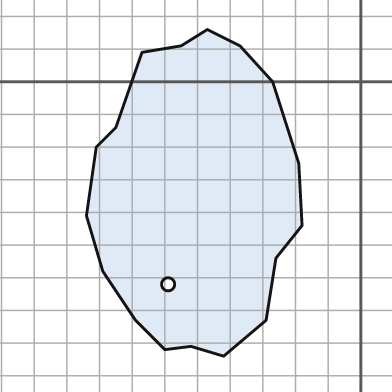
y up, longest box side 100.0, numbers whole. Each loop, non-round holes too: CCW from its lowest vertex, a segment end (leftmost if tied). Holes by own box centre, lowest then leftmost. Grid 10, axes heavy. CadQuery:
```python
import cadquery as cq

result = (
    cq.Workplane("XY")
    .moveTo(-42.0, -84.0)
    .lineTo(-29.0, -73.0)
    .lineTo(-26.0, -54.0)
    .lineTo(-18.0, -44.0)
    .lineTo(-19.0, -25.0)
    .lineTo(-27.0, 0.0)
    .lineTo(-37.0, 11.0)
    .lineTo(-47.0, 16.0)
    .lineTo(-55.0, 11.0)
    .lineTo(-67.0, 9.0)
    .lineTo(-75.0, -14.0)
    .lineTo(-81.0, -20.0)
    .lineTo(-84.0, -41.0)
    .lineTo(-79.0, -58.0)
    .lineTo(-69.0, -73.0)
    .lineTo(-60.0, -82.0)
    .lineTo(-52.0, -81.0)
    .close()
    .moveTo(-59.0, -62.0)
    .circle(2.0)
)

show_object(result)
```